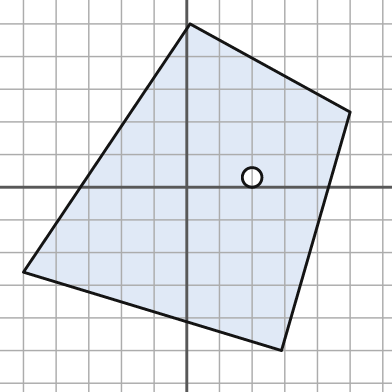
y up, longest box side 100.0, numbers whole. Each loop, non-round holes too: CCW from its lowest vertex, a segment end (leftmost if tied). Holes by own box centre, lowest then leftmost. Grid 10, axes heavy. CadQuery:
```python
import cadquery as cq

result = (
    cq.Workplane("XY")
    .moveTo(29.0, -50.0)
    .lineTo(50.0, 23.0)
    .lineTo(1.0, 50.0)
    .lineTo(-50.0, -26.0)
    .close()
    .moveTo(20.0, 3.0)
    .circle(3.0)
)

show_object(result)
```